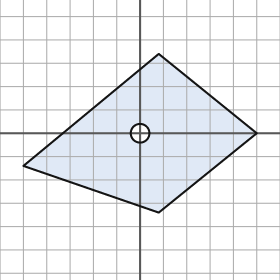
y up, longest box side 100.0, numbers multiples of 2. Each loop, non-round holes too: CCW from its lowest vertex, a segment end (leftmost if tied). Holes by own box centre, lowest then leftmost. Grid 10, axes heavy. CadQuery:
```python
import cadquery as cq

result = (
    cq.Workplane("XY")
    .moveTo(8.0, -34.0)
    .lineTo(50.0, 0.0)
    .lineTo(8.0, 34.0)
    .lineTo(-50.0, -14.0)
    .close()
    .moveTo(0.0, 0.0)
    .circle(4.0)
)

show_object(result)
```